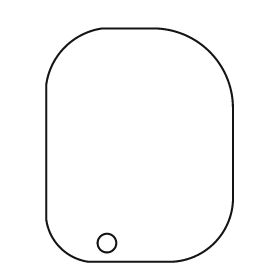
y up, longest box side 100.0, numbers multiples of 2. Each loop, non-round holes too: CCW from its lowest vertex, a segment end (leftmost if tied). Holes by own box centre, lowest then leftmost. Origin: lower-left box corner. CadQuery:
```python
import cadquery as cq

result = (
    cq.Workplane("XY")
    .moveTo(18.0, 0.0)
    .lineTo(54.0, 0.0)
    .threePointArc((72.0, 8.0), (80.0, 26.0))
    .lineTo(80.0, 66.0)
    .threePointArc((70.0, 90.0), (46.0, 100.0))
    .lineTo(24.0, 100.0)
    .threePointArc((8.0, 92.0), (0.0, 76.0))
    .lineTo(0.0, 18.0)
    .threePointArc((6.0, 6.0), (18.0, 0.0))
    .close()
    .moveTo(26.0, 8.0)
    .circle(4.0)
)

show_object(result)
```